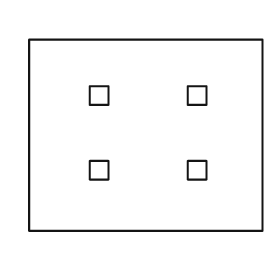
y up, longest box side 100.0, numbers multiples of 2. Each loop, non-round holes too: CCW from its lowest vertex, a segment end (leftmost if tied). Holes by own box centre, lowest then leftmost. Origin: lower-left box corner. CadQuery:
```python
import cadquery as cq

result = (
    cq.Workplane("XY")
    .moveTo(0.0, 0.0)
    .lineTo(100.0, 0.0)
    .lineTo(100.0, 82.0)
    .lineTo(0.0, 82.0)
    .close()
    .moveTo(26.0, 22.0)
    .lineTo(34.0, 22.0)
    .lineTo(34.0, 30.0)
    .lineTo(26.0, 30.0)
    .close()
    .moveTo(68.0, 22.0)
    .lineTo(76.0, 22.0)
    .lineTo(76.0, 30.0)
    .lineTo(68.0, 30.0)
    .close()
    .moveTo(26.0, 54.0)
    .lineTo(34.0, 54.0)
    .lineTo(34.0, 62.0)
    .lineTo(26.0, 62.0)
    .close()
    .moveTo(68.0, 54.0)
    .lineTo(76.0, 54.0)
    .lineTo(76.0, 62.0)
    .lineTo(68.0, 62.0)
    .close()
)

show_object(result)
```